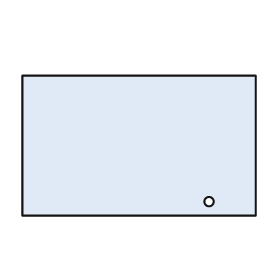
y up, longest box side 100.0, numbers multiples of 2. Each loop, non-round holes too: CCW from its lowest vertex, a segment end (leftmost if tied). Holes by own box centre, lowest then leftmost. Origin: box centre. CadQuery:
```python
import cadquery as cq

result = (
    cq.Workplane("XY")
    .moveTo(-50.0, -30.0)
    .lineTo(50.0, -30.0)
    .lineTo(50.0, 30.0)
    .lineTo(-50.0, 30.0)
    .close()
    .moveTo(30.0, -24.0)
    .circle(2.0)
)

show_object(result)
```